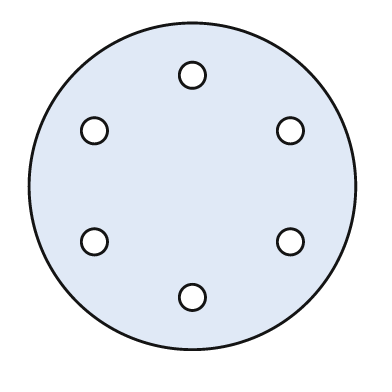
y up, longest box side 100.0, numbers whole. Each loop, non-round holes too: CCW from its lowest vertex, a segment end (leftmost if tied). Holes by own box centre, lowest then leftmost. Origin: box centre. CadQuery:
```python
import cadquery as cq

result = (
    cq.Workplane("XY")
    .moveTo(0.0, 0.0)
    .circle(50.0)
    .moveTo(0.0, -34.0)
    .circle(4.0)
    .moveTo(-30.0, -17.0)
    .circle(4.0)
    .moveTo(30.0, -17.0)
    .circle(4.0)
    .moveTo(-30.0, 17.0)
    .circle(4.0)
    .moveTo(30.0, 17.0)
    .circle(4.0)
    .moveTo(0.0, 34.0)
    .circle(4.0)
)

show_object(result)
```